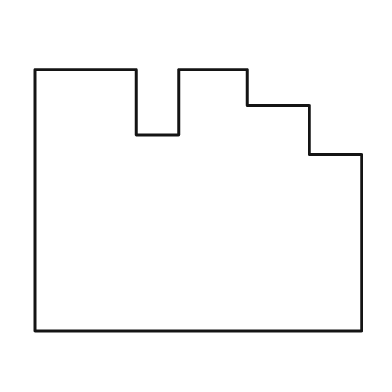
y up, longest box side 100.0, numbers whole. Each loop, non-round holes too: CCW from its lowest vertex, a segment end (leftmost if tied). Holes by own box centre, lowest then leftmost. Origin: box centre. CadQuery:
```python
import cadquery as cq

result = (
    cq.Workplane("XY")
    .moveTo(-50.0, -40.0)
    .lineTo(50.0, -40.0)
    .lineTo(50.0, 14.0)
    .lineTo(34.0, 14.0)
    .lineTo(34.0, 29.0)
    .lineTo(15.0, 29.0)
    .lineTo(15.0, 40.0)
    .lineTo(-6.0, 40.0)
    .lineTo(-6.0, 20.0)
    .lineTo(-19.0, 20.0)
    .lineTo(-19.0, 40.0)
    .lineTo(-50.0, 40.0)
    .close()
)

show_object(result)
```